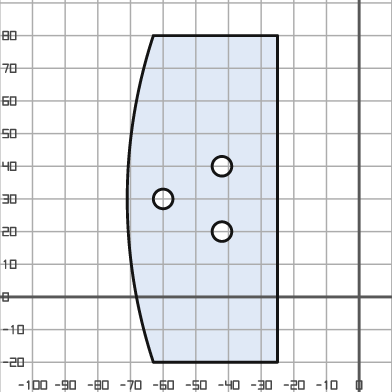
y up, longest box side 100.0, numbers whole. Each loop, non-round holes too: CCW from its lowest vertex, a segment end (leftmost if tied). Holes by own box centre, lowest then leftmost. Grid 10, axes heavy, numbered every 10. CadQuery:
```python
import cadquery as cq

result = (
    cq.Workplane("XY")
    .moveTo(-63.0, -20.0)
    .lineTo(-25.0, -20.0)
    .lineTo(-25.0, 80.0)
    .lineTo(-63.0, 80.0)
    .threePointArc((-71.0, 30.0), (-63.0, -20.0))
    .close()
    .moveTo(-42.0, 20.0)
    .circle(3.0)
    .moveTo(-60.0, 30.0)
    .circle(3.0)
    .moveTo(-42.0, 40.0)
    .circle(3.0)
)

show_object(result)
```